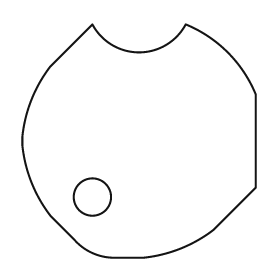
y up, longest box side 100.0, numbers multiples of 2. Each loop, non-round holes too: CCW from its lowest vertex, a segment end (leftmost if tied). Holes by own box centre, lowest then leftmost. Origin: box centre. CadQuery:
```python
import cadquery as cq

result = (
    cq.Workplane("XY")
    .moveTo(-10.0, -50.0)
    .lineTo(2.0, -50.0)
    .threePointArc((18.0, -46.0), (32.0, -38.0))
    .lineTo(50.0, -20.0)
    .lineTo(50.0, 20.0)
    .threePointArc((38.0, 38.0), (20.0, 50.0))
    .threePointArc((0.0, 38.0), (-20.0, 50.0))
    .lineTo(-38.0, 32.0)
    .threePointArc((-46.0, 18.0), (-50.0, 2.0))
    .lineTo(-50.0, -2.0)
    .threePointArc((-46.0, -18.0), (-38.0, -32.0))
    .lineTo(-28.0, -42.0)
    .threePointArc((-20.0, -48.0), (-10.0, -50.0))
    .close()
    .moveTo(-20.0, -24.0)
    .circle(8.0)
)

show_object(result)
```